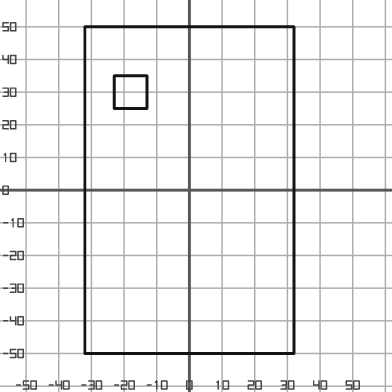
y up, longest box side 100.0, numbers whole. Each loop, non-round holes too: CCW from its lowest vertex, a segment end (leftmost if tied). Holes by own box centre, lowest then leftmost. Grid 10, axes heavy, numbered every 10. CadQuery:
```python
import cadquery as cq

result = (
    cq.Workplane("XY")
    .moveTo(-32.0, -50.0)
    .lineTo(32.0, -50.0)
    .lineTo(32.0, 50.0)
    .lineTo(-32.0, 50.0)
    .close()
    .moveTo(-23.0, 25.0)
    .lineTo(-13.0, 25.0)
    .lineTo(-13.0, 35.0)
    .lineTo(-23.0, 35.0)
    .close()
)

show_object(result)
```